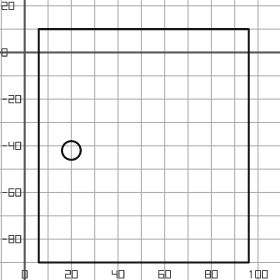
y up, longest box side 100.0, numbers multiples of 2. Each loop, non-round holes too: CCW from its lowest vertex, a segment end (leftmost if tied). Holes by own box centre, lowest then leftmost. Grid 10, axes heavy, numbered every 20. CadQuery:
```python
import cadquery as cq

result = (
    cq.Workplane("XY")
    .moveTo(6.0, -90.0)
    .lineTo(96.0, -90.0)
    .lineTo(96.0, 10.0)
    .lineTo(6.0, 10.0)
    .close()
    .moveTo(20.0, -42.0)
    .circle(4.0)
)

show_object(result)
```